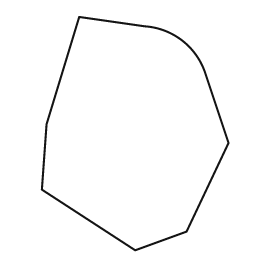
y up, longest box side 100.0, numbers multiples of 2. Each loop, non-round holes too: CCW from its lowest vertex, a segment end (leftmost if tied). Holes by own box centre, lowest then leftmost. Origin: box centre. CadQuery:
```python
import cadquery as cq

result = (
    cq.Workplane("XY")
    .moveTo(0.0, -50.0)
    .lineTo(22.0, -42.0)
    .lineTo(40.0, -4.0)
    .lineTo(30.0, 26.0)
    .threePointArc((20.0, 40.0), (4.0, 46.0))
    .lineTo(-24.0, 50.0)
    .lineTo(-38.0, 4.0)
    .lineTo(-40.0, -24.0)
    .close()
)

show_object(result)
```